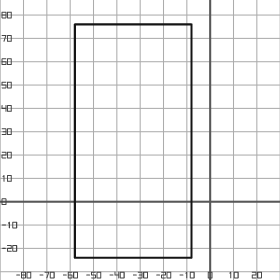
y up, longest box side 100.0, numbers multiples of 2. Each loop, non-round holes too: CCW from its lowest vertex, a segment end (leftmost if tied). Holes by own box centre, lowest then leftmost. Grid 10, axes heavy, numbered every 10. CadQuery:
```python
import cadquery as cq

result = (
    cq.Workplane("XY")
    .moveTo(-58.0, -24.0)
    .lineTo(-8.0, -24.0)
    .lineTo(-8.0, 76.0)
    .lineTo(-58.0, 76.0)
    .close()
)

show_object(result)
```